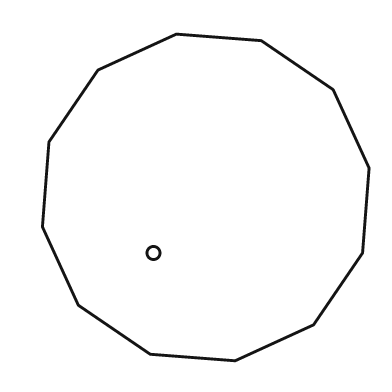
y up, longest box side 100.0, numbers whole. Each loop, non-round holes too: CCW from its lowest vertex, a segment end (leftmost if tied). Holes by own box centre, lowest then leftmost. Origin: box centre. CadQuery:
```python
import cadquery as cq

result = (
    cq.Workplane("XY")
    .moveTo(9.0, -50.0)
    .lineTo(33.0, -39.0)
    .lineTo(48.0, -17.0)
    .lineTo(50.0, 9.0)
    .lineTo(39.0, 33.0)
    .lineTo(17.0, 48.0)
    .lineTo(-9.0, 50.0)
    .lineTo(-33.0, 39.0)
    .lineTo(-48.0, 17.0)
    .lineTo(-50.0, -9.0)
    .lineTo(-39.0, -33.0)
    .lineTo(-17.0, -48.0)
    .close()
    .moveTo(-16.0, -17.0)
    .circle(2.0)
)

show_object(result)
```